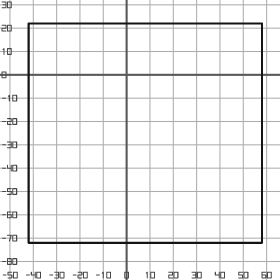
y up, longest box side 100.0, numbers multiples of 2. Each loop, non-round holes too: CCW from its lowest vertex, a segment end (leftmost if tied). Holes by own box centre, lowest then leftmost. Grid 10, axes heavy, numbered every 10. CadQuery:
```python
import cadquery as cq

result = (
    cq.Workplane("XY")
    .moveTo(-42.0, -72.0)
    .lineTo(58.0, -72.0)
    .lineTo(58.0, 22.0)
    .lineTo(-42.0, 22.0)
    .close()
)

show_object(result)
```